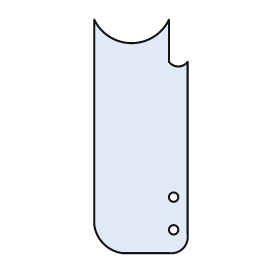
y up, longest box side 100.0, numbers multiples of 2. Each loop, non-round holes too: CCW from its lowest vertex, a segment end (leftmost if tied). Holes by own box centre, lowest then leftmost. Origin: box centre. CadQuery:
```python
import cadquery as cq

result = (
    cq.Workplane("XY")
    .moveTo(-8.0, -50.0)
    .lineTo(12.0, -50.0)
    .threePointArc((18.0, -48.0), (20.0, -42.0))
    .lineTo(20.0, 32.0)
    .threePointArc((16.0, 30.0), (12.0, 32.0))
    .lineTo(12.0, 50.0)
    .threePointArc((-4.0, 40.0), (-20.0, 50.0))
    .lineTo(-20.0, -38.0)
    .threePointArc((-16.0, -46.0), (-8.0, -50.0))
    .close()
    .moveTo(14.0, -40.0)
    .circle(2.0)
    .moveTo(14.0, -26.0)
    .circle(2.0)
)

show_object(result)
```